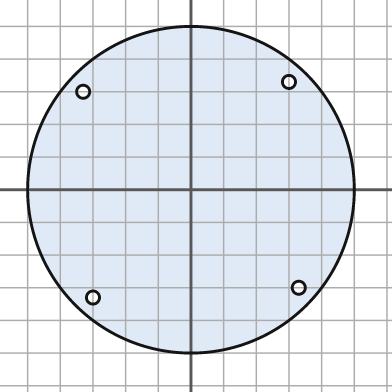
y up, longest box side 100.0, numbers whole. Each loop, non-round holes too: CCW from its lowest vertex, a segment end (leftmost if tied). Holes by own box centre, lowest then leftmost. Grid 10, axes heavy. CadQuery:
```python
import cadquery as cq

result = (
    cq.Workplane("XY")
    .moveTo(0.0, 0.0)
    .circle(50.0)
    .moveTo(-30.0, -33.0)
    .circle(2.0)
    .moveTo(33.0, -30.0)
    .circle(2.0)
    .moveTo(-33.0, 30.0)
    .circle(2.0)
    .moveTo(30.0, 33.0)
    .circle(2.0)
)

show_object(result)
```